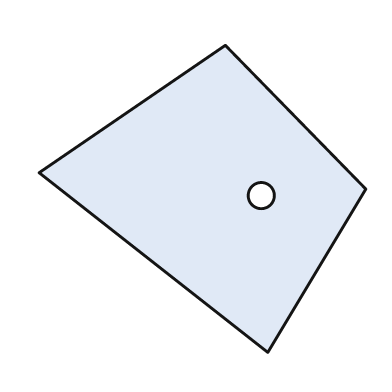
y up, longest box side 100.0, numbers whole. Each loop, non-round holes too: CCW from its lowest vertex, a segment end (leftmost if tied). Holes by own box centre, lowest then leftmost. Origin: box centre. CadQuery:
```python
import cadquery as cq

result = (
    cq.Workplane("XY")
    .moveTo(20.0, -47.0)
    .lineTo(50.0, 3.0)
    .lineTo(7.0, 47.0)
    .lineTo(-50.0, 8.0)
    .close()
    .moveTo(18.0, 1.0)
    .circle(4.0)
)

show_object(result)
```